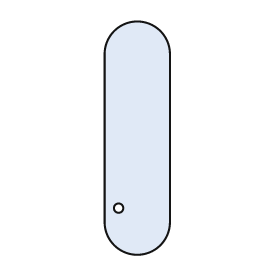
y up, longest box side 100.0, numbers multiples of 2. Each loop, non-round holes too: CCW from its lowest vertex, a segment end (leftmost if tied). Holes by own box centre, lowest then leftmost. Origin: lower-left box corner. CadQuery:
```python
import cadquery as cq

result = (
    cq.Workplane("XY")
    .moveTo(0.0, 14.0)
    .threePointArc((14.0, 0.0), (28.0, 14.0))
    .lineTo(28.0, 86.0)
    .threePointArc((14.0, 100.0), (0.0, 86.0))
    .close()
    .moveTo(6.0, 20.0)
    .circle(2.0)
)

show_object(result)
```